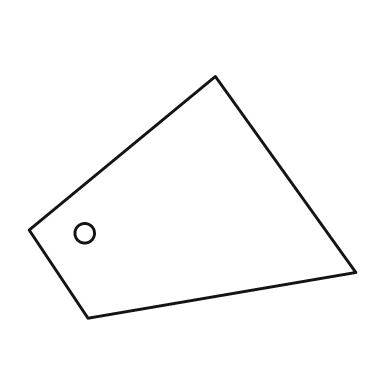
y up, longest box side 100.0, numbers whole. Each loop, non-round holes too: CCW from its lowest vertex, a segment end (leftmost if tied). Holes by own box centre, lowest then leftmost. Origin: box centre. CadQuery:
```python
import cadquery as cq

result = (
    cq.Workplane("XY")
    .moveTo(-32.0, -37.0)
    .lineTo(50.0, -23.0)
    .lineTo(7.0, 37.0)
    .lineTo(-50.0, -10.0)
    .close()
    .moveTo(-33.0, -11.0)
    .circle(3.0)
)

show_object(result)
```